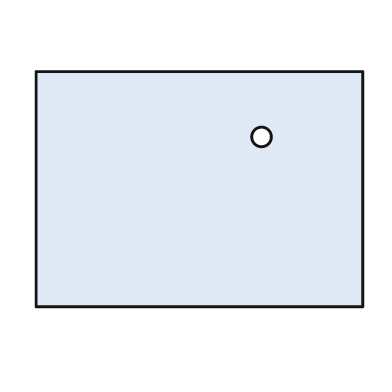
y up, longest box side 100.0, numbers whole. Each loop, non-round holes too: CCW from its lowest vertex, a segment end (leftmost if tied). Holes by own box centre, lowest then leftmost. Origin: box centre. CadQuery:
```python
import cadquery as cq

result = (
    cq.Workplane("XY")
    .moveTo(-50.0, -36.0)
    .lineTo(50.0, -36.0)
    .lineTo(50.0, 36.0)
    .lineTo(-50.0, 36.0)
    .close()
    .moveTo(19.0, 16.0)
    .circle(3.0)
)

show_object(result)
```